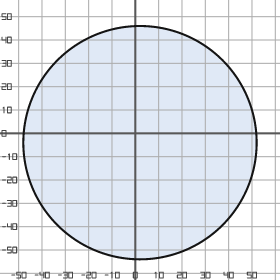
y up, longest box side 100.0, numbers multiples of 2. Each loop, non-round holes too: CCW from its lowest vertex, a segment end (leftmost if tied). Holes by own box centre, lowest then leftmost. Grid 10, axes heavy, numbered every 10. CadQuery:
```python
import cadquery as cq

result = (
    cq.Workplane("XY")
    .moveTo(2.0, -4.0)
    .circle(50.0)
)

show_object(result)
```